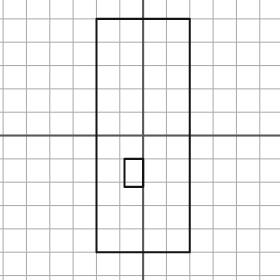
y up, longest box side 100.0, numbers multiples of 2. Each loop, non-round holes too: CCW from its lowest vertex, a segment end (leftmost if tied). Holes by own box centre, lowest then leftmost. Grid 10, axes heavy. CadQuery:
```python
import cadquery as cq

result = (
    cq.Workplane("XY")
    .moveTo(-20.0, -50.0)
    .lineTo(20.0, -50.0)
    .lineTo(20.0, 50.0)
    .lineTo(-20.0, 50.0)
    .close()
    .moveTo(-8.0, -22.0)
    .lineTo(0.0, -22.0)
    .lineTo(0.0, -10.0)
    .lineTo(-8.0, -10.0)
    .close()
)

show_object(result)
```